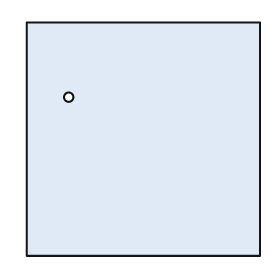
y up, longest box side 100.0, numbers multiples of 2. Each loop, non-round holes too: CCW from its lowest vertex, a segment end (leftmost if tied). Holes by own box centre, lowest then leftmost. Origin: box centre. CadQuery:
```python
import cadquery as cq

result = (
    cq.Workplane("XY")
    .moveTo(-50.0, -50.0)
    .lineTo(50.0, -50.0)
    .lineTo(50.0, 50.0)
    .lineTo(-50.0, 50.0)
    .close()
    .moveTo(-32.0, 18.0)
    .circle(2.0)
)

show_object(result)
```